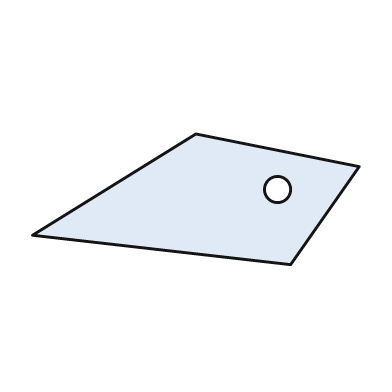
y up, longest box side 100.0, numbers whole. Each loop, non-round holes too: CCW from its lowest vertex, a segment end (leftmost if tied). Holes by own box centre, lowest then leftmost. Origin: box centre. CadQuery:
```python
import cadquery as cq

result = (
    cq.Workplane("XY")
    .moveTo(29.0, -20.0)
    .lineTo(50.0, 10.0)
    .lineTo(0.0, 20.0)
    .lineTo(-50.0, -11.0)
    .close()
    .moveTo(25.0, 3.0)
    .circle(4.0)
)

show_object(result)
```